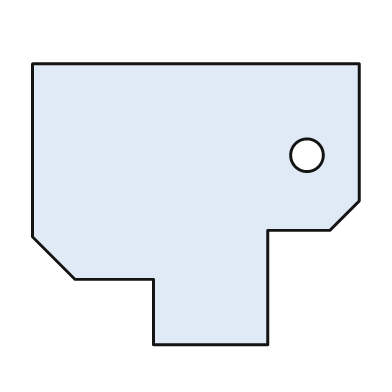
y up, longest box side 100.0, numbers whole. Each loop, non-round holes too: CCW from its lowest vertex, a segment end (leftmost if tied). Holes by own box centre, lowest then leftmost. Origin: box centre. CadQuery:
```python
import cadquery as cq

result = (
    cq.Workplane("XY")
    .moveTo(-13.0, -43.0)
    .lineTo(22.0, -43.0)
    .lineTo(22.0, -8.0)
    .lineTo(41.0, -8.0)
    .lineTo(50.0, 1.0)
    .lineTo(50.0, 43.0)
    .lineTo(-50.0, 43.0)
    .lineTo(-50.0, -10.0)
    .lineTo(-37.0, -23.0)
    .lineTo(-13.0, -23.0)
    .close()
    .moveTo(34.0, 15.0)
    .circle(5.0)
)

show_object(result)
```